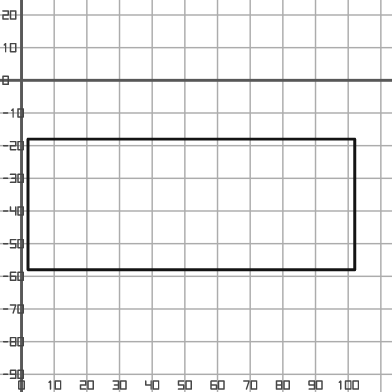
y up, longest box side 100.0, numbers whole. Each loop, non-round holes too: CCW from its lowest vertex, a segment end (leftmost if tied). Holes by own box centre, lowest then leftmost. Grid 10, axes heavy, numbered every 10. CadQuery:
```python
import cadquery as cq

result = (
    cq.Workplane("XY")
    .moveTo(2.0, -58.0)
    .lineTo(102.0, -58.0)
    .lineTo(102.0, -18.0)
    .lineTo(2.0, -18.0)
    .close()
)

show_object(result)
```